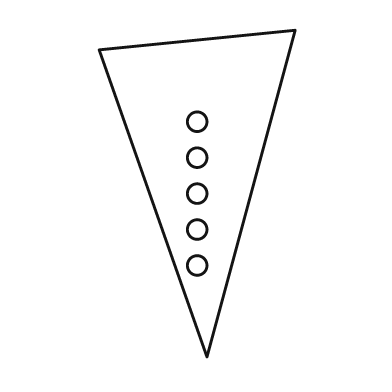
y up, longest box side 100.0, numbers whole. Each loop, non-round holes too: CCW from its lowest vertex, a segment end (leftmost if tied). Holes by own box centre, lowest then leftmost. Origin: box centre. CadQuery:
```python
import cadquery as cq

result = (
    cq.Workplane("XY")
    .moveTo(3.0, -50.0)
    .lineTo(30.0, 50.0)
    .lineTo(-30.0, 44.0)
    .close()
    .moveTo(0.0, -22.0)
    .circle(3.0)
    .moveTo(0.0, -11.0)
    .circle(3.0)
    .moveTo(0.0, 0.0)
    .circle(3.0)
    .moveTo(0.0, 11.0)
    .circle(3.0)
    .moveTo(0.0, 22.0)
    .circle(3.0)
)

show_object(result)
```